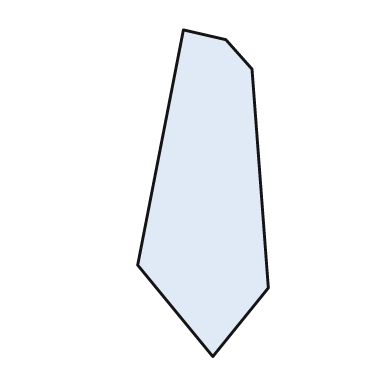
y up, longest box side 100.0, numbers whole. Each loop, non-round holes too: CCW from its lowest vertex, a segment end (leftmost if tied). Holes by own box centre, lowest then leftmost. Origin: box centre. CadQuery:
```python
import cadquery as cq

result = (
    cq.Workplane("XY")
    .moveTo(3.0, -50.0)
    .lineTo(20.0, -29.0)
    .lineTo(15.0, 38.0)
    .lineTo(7.0, 47.0)
    .lineTo(-6.0, 50.0)
    .lineTo(-20.0, -22.0)
    .close()
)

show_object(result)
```